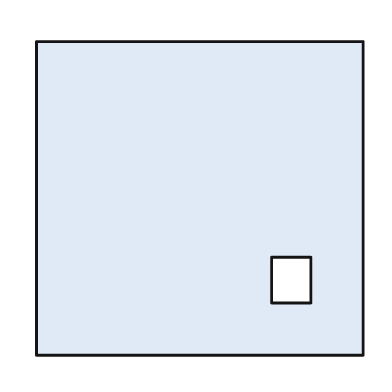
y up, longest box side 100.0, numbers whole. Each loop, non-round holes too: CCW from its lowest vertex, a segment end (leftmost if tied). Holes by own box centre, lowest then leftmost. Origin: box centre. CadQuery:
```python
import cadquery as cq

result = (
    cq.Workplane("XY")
    .moveTo(-50.0, -48.0)
    .lineTo(50.0, -48.0)
    .lineTo(50.0, 48.0)
    .lineTo(-50.0, 48.0)
    .close()
    .moveTo(22.0, -32.0)
    .lineTo(34.0, -32.0)
    .lineTo(34.0, -18.0)
    .lineTo(22.0, -18.0)
    .close()
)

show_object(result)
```